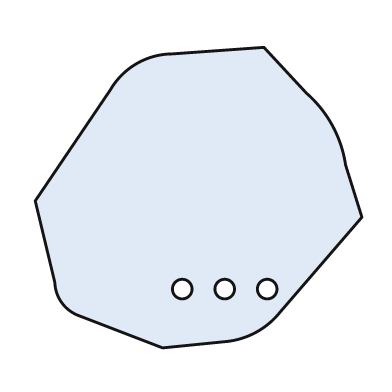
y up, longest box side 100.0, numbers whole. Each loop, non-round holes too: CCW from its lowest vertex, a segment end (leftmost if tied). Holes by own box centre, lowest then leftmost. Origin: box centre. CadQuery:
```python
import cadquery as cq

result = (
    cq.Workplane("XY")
    .moveTo(-11.0, -46.0)
    .lineTo(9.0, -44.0)
    .threePointArc((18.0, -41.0), (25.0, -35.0))
    .lineTo(50.0, -6.0)
    .lineTo(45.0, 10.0)
    .threePointArc((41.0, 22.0), (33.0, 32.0))
    .lineTo(20.0, 46.0)
    .lineTo(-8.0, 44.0)
    .threePointArc((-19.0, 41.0), (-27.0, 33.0))
    .lineTo(-50.0, -1.0)
    .lineTo(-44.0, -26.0)
    .threePointArc((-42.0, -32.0), (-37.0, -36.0))
    .close()
    .moveTo(-5.0, -28.0)
    .circle(3.0)
    .moveTo(8.0, -28.0)
    .circle(3.0)
    .moveTo(21.0, -28.0)
    .circle(3.0)
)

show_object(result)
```